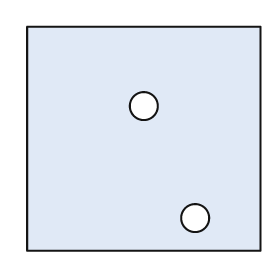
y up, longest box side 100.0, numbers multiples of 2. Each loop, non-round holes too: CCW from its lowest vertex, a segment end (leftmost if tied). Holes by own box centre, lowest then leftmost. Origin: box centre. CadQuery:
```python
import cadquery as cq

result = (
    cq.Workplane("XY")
    .moveTo(-50.0, -48.0)
    .lineTo(50.0, -48.0)
    .lineTo(50.0, 48.0)
    .lineTo(-50.0, 48.0)
    .close()
    .moveTo(22.0, -34.0)
    .circle(6.0)
    .moveTo(0.0, 14.0)
    .circle(6.0)
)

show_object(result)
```